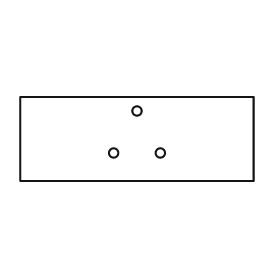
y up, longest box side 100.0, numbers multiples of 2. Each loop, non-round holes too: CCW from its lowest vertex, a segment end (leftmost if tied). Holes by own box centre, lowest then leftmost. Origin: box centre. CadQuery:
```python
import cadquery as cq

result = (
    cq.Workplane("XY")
    .moveTo(-50.0, -18.0)
    .lineTo(50.0, -18.0)
    .lineTo(50.0, 18.0)
    .lineTo(-50.0, 18.0)
    .close()
    .moveTo(-10.0, -6.0)
    .circle(2.0)
    .moveTo(10.0, -6.0)
    .circle(2.0)
    .moveTo(0.0, 12.0)
    .circle(2.0)
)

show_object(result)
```